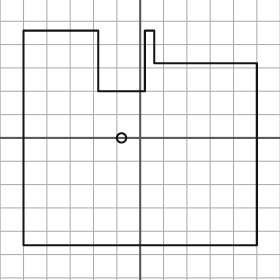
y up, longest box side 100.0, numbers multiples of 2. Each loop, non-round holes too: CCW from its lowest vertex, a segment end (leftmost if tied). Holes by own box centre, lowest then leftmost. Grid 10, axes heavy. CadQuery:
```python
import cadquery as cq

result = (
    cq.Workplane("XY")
    .moveTo(-50.0, -46.0)
    .lineTo(50.0, -46.0)
    .lineTo(50.0, 32.0)
    .lineTo(6.0, 32.0)
    .lineTo(6.0, 46.0)
    .lineTo(2.0, 46.0)
    .lineTo(2.0, 20.0)
    .lineTo(-18.0, 20.0)
    .lineTo(-18.0, 46.0)
    .lineTo(-50.0, 46.0)
    .close()
    .moveTo(-8.0, 0.0)
    .circle(2.0)
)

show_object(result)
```